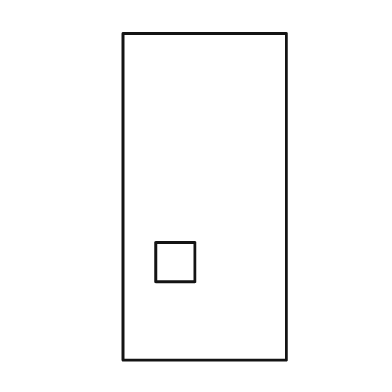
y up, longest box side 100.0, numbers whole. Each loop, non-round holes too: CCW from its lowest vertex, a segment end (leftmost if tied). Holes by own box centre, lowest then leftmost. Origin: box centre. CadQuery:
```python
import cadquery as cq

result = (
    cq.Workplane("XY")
    .moveTo(-25.0, -50.0)
    .lineTo(25.0, -50.0)
    .lineTo(25.0, 50.0)
    .lineTo(-25.0, 50.0)
    .close()
    .moveTo(-15.0, -26.0)
    .lineTo(-3.0, -26.0)
    .lineTo(-3.0, -14.0)
    .lineTo(-15.0, -14.0)
    .close()
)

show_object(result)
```